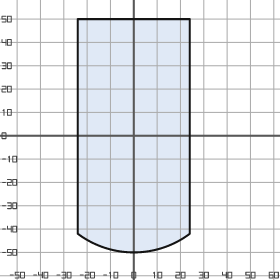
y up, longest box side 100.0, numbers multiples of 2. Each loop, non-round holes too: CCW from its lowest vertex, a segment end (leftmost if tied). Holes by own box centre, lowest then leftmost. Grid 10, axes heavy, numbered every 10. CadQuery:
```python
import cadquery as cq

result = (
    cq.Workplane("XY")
    .moveTo(-24.0, -42.0)
    .threePointArc((0.0, -50.0), (24.0, -42.0))
    .lineTo(24.0, 50.0)
    .lineTo(-24.0, 50.0)
    .close()
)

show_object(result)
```